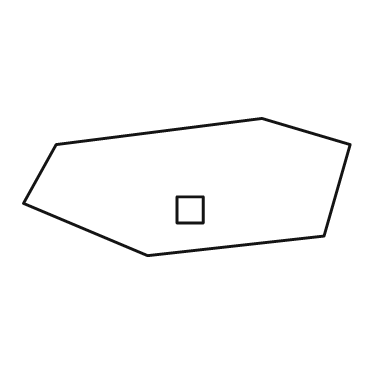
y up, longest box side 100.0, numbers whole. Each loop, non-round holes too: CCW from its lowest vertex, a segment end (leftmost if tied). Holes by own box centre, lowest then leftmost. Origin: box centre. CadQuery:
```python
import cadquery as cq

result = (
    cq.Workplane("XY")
    .moveTo(-12.0, -21.0)
    .lineTo(42.0, -15.0)
    .lineTo(50.0, 13.0)
    .lineTo(23.0, 21.0)
    .lineTo(-40.0, 13.0)
    .lineTo(-50.0, -5.0)
    .close()
    .moveTo(-3.0, -11.0)
    .lineTo(5.0, -11.0)
    .lineTo(5.0, -3.0)
    .lineTo(-3.0, -3.0)
    .close()
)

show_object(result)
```